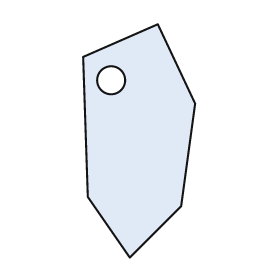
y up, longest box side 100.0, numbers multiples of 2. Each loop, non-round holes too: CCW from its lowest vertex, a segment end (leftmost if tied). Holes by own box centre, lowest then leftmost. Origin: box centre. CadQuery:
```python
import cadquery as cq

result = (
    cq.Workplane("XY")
    .moveTo(-4.0, -50.0)
    .lineTo(18.0, -28.0)
    .lineTo(24.0, 16.0)
    .lineTo(8.0, 50.0)
    .lineTo(-24.0, 36.0)
    .lineTo(-22.0, -24.0)
    .close()
    .moveTo(-12.0, 26.0)
    .circle(6.0)
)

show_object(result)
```